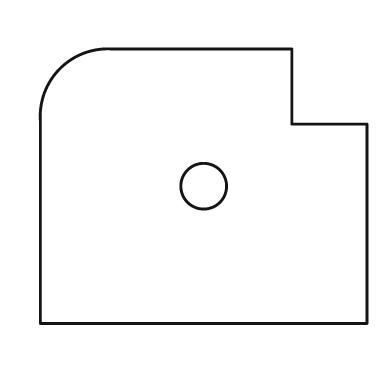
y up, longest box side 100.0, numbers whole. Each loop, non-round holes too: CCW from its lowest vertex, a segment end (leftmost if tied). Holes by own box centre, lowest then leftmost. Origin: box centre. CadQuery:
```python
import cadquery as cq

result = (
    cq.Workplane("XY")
    .moveTo(-50.0, -42.0)
    .lineTo(50.0, -42.0)
    .lineTo(50.0, 19.0)
    .lineTo(27.0, 19.0)
    .lineTo(27.0, 42.0)
    .lineTo(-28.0, 42.0)
    .threePointArc((-44.0, 36.0), (-50.0, 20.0))
    .close()
    .moveTo(0.0, 0.0)
    .circle(7.0)
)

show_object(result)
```